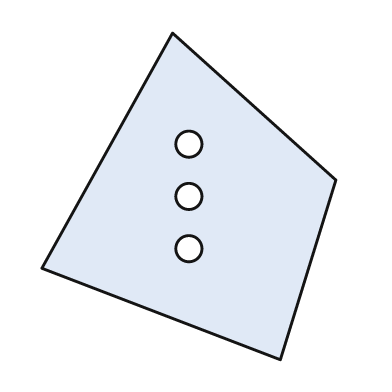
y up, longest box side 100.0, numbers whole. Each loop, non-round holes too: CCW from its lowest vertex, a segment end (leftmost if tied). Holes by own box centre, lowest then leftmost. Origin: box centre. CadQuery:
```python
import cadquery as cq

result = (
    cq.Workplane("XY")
    .moveTo(28.0, -50.0)
    .lineTo(45.0, 5.0)
    .lineTo(-5.0, 50.0)
    .lineTo(-45.0, -22.0)
    .close()
    .moveTo(0.0, -16.0)
    .circle(4.0)
    .moveTo(0.0, 0.0)
    .circle(4.0)
    .moveTo(0.0, 16.0)
    .circle(4.0)
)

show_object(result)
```